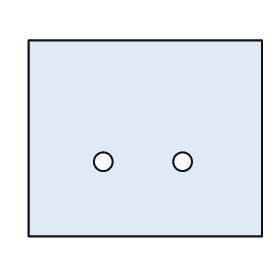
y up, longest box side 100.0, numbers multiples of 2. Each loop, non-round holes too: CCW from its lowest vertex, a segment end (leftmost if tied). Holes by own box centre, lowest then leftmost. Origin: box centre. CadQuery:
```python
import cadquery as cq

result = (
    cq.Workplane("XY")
    .moveTo(-50.0, -42.0)
    .lineTo(50.0, -42.0)
    .lineTo(50.0, 42.0)
    .lineTo(-50.0, 42.0)
    .close()
    .moveTo(-18.0, -10.0)
    .circle(4.0)
    .moveTo(16.0, -10.0)
    .circle(4.0)
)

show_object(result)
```